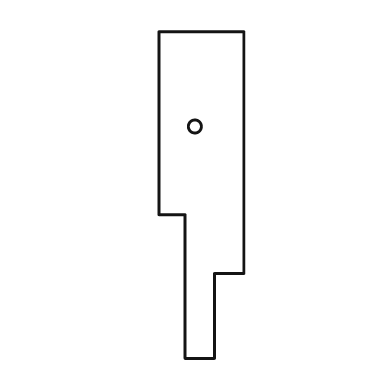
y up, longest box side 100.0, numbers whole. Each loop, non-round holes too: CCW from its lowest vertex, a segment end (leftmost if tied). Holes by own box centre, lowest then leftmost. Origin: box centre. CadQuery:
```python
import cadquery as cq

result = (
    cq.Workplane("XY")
    .moveTo(-5.0, -50.0)
    .lineTo(4.0, -50.0)
    .lineTo(4.0, -24.0)
    .lineTo(13.0, -24.0)
    .lineTo(13.0, 50.0)
    .lineTo(-13.0, 50.0)
    .lineTo(-13.0, -6.0)
    .lineTo(-5.0, -6.0)
    .close()
    .moveTo(-2.0, 21.0)
    .circle(2.0)
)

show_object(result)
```